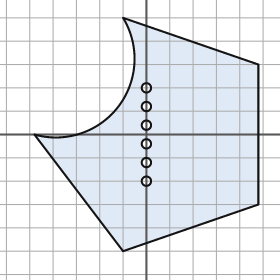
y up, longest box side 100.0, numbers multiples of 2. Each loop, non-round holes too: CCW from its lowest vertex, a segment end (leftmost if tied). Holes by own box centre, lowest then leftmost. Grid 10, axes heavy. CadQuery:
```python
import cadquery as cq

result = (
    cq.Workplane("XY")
    .moveTo(-10.0, -50.0)
    .lineTo(48.0, -30.0)
    .lineTo(48.0, 30.0)
    .lineTo(-10.0, 50.0)
    .threePointArc((-12.0, 12.0), (-48.0, 0.0))
    .close()
    .moveTo(0.0, -20.0)
    .circle(2.0)
    .moveTo(0.0, -12.0)
    .circle(2.0)
    .moveTo(0.0, -4.0)
    .circle(2.0)
    .moveTo(0.0, 4.0)
    .circle(2.0)
    .moveTo(0.0, 12.0)
    .circle(2.0)
    .moveTo(0.0, 20.0)
    .circle(2.0)
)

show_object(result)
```